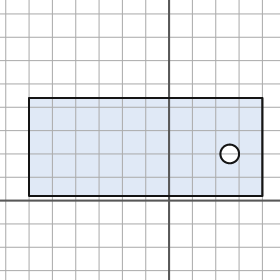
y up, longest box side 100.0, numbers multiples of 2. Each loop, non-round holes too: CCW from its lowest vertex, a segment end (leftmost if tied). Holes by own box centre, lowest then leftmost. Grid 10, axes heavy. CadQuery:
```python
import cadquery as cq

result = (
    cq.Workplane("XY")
    .moveTo(-60.0, 2.0)
    .lineTo(40.0, 2.0)
    .lineTo(40.0, 44.0)
    .lineTo(-60.0, 44.0)
    .close()
    .moveTo(26.0, 20.0)
    .circle(4.0)
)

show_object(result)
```